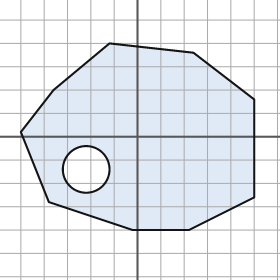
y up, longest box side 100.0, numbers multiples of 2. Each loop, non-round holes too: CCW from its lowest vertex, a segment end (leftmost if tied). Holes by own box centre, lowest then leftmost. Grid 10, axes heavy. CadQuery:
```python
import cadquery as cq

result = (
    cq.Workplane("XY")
    .moveTo(-2.0, -40.0)
    .lineTo(22.0, -40.0)
    .lineTo(50.0, -26.0)
    .lineTo(50.0, 16.0)
    .lineTo(24.0, 36.0)
    .lineTo(-12.0, 40.0)
    .lineTo(-36.0, 20.0)
    .lineTo(-50.0, 2.0)
    .lineTo(-38.0, -28.0)
    .close()
    .moveTo(-22.0, -14.0)
    .circle(10.0)
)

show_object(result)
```